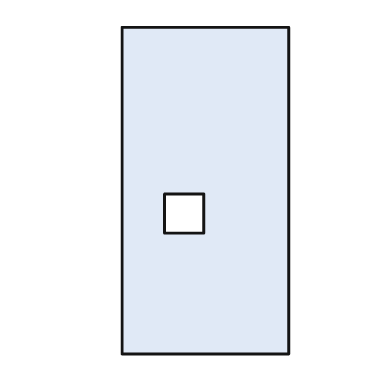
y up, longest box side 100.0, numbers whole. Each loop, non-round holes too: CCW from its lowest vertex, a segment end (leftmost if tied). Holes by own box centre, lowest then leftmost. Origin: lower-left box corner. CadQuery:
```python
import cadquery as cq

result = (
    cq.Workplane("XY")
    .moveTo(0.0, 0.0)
    .lineTo(51.0, 0.0)
    .lineTo(51.0, 100.0)
    .lineTo(0.0, 100.0)
    .close()
    .moveTo(13.0, 37.0)
    .lineTo(25.0, 37.0)
    .lineTo(25.0, 49.0)
    .lineTo(13.0, 49.0)
    .close()
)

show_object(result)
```